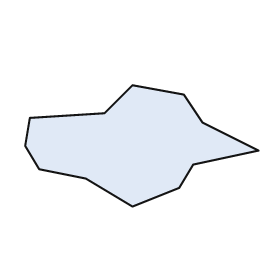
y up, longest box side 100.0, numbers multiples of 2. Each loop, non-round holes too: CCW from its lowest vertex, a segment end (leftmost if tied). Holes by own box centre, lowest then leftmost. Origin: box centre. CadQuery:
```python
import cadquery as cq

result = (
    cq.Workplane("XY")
    .moveTo(-4.0, -26.0)
    .lineTo(16.0, -18.0)
    .lineTo(22.0, -8.0)
    .lineTo(50.0, -2.0)
    .lineTo(26.0, 10.0)
    .lineTo(18.0, 22.0)
    .lineTo(-4.0, 26.0)
    .lineTo(-16.0, 14.0)
    .lineTo(-48.0, 12.0)
    .lineTo(-50.0, 0.0)
    .lineTo(-44.0, -10.0)
    .lineTo(-24.0, -14.0)
    .close()
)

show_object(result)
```